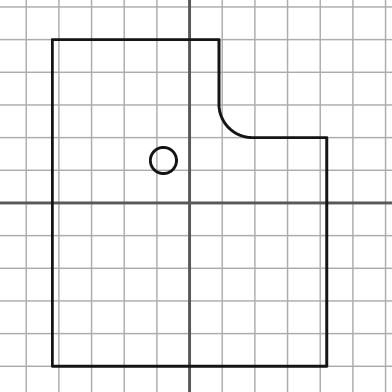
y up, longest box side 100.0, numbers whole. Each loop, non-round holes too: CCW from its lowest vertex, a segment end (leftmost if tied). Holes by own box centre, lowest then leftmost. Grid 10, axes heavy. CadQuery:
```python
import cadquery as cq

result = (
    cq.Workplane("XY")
    .moveTo(-42.0, -50.0)
    .lineTo(42.0, -50.0)
    .lineTo(42.0, 20.0)
    .lineTo(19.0, 20.0)
    .threePointArc((12.0, 23.0), (9.0, 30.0))
    .lineTo(9.0, 50.0)
    .lineTo(-42.0, 50.0)
    .close()
    .moveTo(-8.0, 13.0)
    .circle(4.0)
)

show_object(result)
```